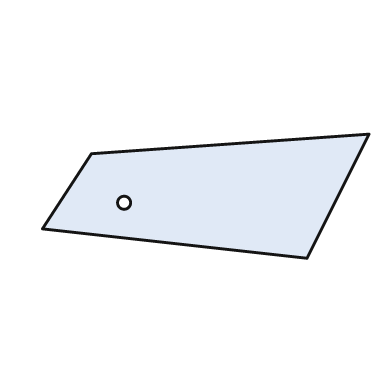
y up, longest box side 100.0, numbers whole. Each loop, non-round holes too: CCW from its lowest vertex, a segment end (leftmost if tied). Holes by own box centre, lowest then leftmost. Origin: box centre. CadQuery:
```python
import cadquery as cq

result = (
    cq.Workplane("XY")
    .moveTo(31.0, -19.0)
    .lineTo(50.0, 19.0)
    .lineTo(-35.0, 13.0)
    .lineTo(-50.0, -10.0)
    .close()
    .moveTo(-25.0, -2.0)
    .circle(2.0)
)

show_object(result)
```